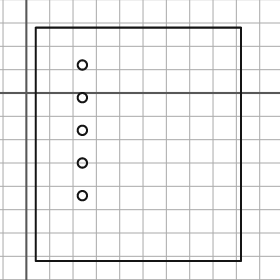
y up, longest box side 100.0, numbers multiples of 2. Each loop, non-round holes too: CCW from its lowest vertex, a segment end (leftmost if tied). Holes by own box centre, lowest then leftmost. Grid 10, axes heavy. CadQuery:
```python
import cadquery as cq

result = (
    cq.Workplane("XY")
    .moveTo(4.0, -72.0)
    .lineTo(92.0, -72.0)
    .lineTo(92.0, 28.0)
    .lineTo(4.0, 28.0)
    .close()
    .moveTo(24.0, -44.0)
    .circle(2.0)
    .moveTo(24.0, -30.0)
    .circle(2.0)
    .moveTo(24.0, -16.0)
    .circle(2.0)
    .moveTo(24.0, -2.0)
    .circle(2.0)
    .moveTo(24.0, 12.0)
    .circle(2.0)
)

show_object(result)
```